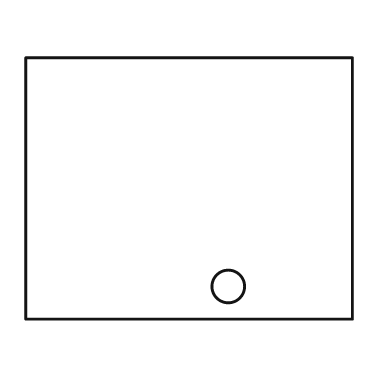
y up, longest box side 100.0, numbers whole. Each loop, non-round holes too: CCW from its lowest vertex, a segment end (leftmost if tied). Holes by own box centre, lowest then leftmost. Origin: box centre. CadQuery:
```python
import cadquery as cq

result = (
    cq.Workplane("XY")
    .moveTo(-50.0, -40.0)
    .lineTo(50.0, -40.0)
    .lineTo(50.0, 40.0)
    .lineTo(-50.0, 40.0)
    .close()
    .moveTo(12.0, -30.0)
    .circle(5.0)
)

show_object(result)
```